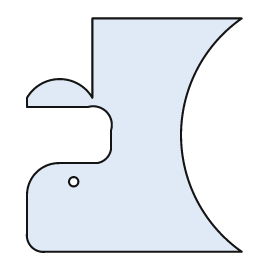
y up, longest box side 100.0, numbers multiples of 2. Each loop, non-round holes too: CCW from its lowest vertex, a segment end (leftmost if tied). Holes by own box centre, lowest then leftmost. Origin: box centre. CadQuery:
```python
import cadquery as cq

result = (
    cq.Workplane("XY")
    .moveTo(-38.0, -50.0)
    .lineTo(46.0, -50.0)
    .threePointArc((20.0, 0.0), (46.0, 50.0))
    .lineTo(-18.0, 50.0)
    .lineTo(-18.0, 16.0)
    .threePointArc((-32.0, 24.0), (-46.0, 16.0))
    .lineTo(-46.0, 12.0)
    .lineTo(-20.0, 12.0)
    .threePointArc((-12.0, 10.0), (-10.0, 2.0))
    .lineTo(-10.0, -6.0)
    .threePointArc((-12.0, -10.0), (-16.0, -12.0))
    .lineTo(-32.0, -12.0)
    .threePointArc((-42.0, -16.0), (-46.0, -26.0))
    .lineTo(-46.0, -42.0)
    .threePointArc((-44.0, -48.0), (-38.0, -50.0))
    .close()
    .moveTo(-26.0, -20.0)
    .circle(2.0)
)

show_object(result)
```